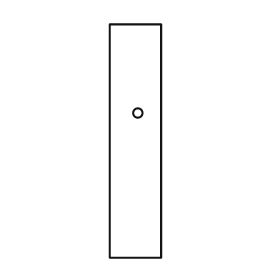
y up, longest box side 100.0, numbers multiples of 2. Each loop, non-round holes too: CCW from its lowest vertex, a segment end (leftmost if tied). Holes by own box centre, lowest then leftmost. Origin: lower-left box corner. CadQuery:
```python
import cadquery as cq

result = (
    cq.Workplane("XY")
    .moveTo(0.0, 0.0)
    .lineTo(22.0, 0.0)
    .lineTo(22.0, 100.0)
    .lineTo(0.0, 100.0)
    .close()
    .moveTo(12.0, 62.0)
    .circle(2.0)
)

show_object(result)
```